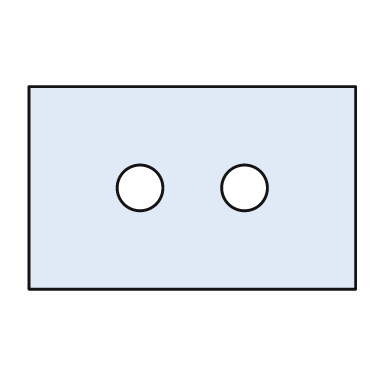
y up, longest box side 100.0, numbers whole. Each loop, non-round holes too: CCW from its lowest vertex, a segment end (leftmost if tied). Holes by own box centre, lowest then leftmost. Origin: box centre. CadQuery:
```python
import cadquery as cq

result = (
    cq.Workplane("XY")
    .moveTo(-50.0, -31.0)
    .lineTo(50.0, -31.0)
    .lineTo(50.0, 31.0)
    .lineTo(-50.0, 31.0)
    .close()
    .moveTo(-16.0, 0.0)
    .circle(7.0)
    .moveTo(16.0, 0.0)
    .circle(7.0)
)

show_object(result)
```